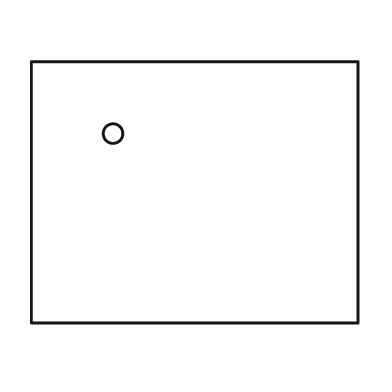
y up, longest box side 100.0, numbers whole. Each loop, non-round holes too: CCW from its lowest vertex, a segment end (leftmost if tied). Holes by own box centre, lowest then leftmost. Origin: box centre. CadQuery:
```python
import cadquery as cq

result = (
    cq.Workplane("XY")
    .moveTo(-50.0, -40.0)
    .lineTo(50.0, -40.0)
    .lineTo(50.0, 40.0)
    .lineTo(-50.0, 40.0)
    .close()
    .moveTo(-25.0, 18.0)
    .circle(3.0)
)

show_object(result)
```